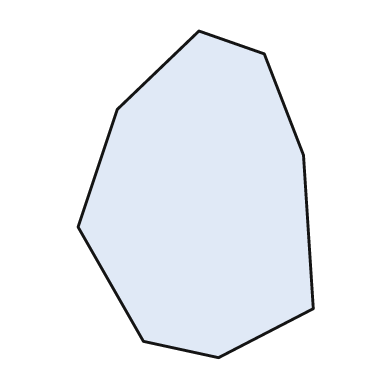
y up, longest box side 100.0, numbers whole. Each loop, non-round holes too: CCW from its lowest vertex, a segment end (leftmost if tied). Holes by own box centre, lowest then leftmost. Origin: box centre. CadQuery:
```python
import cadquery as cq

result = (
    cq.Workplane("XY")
    .moveTo(7.0, -50.0)
    .lineTo(36.0, -35.0)
    .lineTo(33.0, 12.0)
    .lineTo(21.0, 43.0)
    .lineTo(1.0, 50.0)
    .lineTo(-24.0, 26.0)
    .lineTo(-36.0, -10.0)
    .lineTo(-16.0, -45.0)
    .close()
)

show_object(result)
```